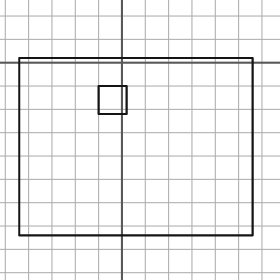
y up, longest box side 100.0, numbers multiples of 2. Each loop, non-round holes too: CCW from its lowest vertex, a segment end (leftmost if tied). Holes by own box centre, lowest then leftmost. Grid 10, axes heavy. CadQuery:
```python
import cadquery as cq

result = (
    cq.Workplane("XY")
    .moveTo(-44.0, -74.0)
    .lineTo(56.0, -74.0)
    .lineTo(56.0, 2.0)
    .lineTo(-44.0, 2.0)
    .close()
    .moveTo(-10.0, -22.0)
    .lineTo(2.0, -22.0)
    .lineTo(2.0, -10.0)
    .lineTo(-10.0, -10.0)
    .close()
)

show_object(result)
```